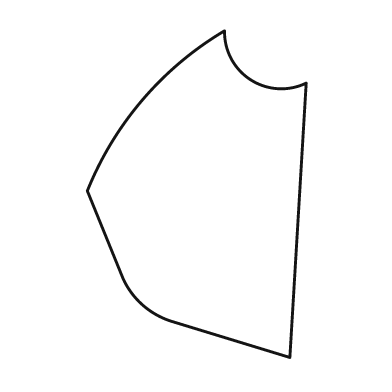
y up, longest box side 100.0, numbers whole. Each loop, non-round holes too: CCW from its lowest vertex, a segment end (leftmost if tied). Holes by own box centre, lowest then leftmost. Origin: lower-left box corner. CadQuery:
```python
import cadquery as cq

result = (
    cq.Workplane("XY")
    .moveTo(62.0, 0.0)
    .lineTo(67.0, 84.0)
    .threePointArc((50.0, 85.0), (42.0, 100.0))
    .threePointArc((17.0, 79.0), (0.0, 51.0))
    .lineTo(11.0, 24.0)
    .threePointArc((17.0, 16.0), (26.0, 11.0))
    .close()
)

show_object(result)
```